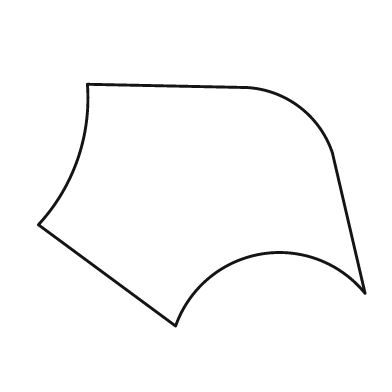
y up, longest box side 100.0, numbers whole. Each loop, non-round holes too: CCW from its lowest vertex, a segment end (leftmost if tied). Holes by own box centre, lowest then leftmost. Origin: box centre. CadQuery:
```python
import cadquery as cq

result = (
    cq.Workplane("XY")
    .moveTo(-8.0, -37.0)
    .threePointArc((18.0, -15.0), (50.0, -27.0))
    .lineTo(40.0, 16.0)
    .threePointArc((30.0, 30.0), (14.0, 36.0))
    .lineTo(-35.0, 37.0)
    .threePointArc((-38.0, 14.0), (-50.0, -6.0))
    .close()
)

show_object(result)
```